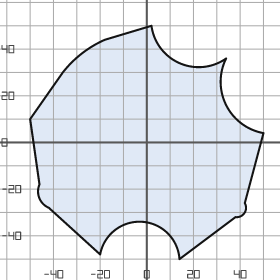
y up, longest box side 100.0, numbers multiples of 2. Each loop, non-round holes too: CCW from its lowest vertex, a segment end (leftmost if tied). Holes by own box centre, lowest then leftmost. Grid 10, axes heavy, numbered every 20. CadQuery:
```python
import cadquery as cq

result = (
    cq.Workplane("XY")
    .moveTo(14.0, -50.0)
    .lineTo(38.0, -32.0)
    .threePointArc((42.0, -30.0), (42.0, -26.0))
    .lineTo(50.0, 4.0)
    .threePointArc((34.0, 16.0), (34.0, 36.0))
    .threePointArc((14.0, 34.0), (2.0, 50.0))
    .lineTo(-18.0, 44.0)
    .threePointArc((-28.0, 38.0), (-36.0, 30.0))
    .lineTo(-50.0, 10.0)
    .lineTo(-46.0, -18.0)
    .threePointArc((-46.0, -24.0), (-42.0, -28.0))
    .lineTo(-20.0, -48.0)
    .threePointArc((-2.0, -34.0), (14.0, -50.0))
    .close()
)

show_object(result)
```